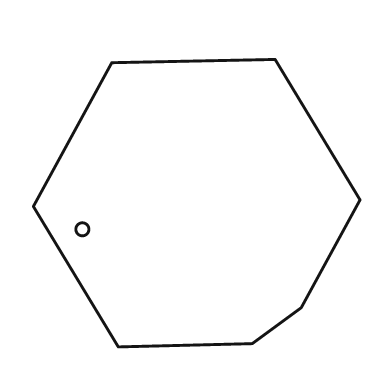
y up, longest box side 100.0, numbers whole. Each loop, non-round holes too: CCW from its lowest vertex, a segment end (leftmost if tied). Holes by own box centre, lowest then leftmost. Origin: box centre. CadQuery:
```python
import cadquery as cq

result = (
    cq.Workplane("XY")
    .moveTo(-24.0, -44.0)
    .lineTo(17.0, -43.0)
    .lineTo(32.0, -32.0)
    .lineTo(50.0, 1.0)
    .lineTo(24.0, 44.0)
    .lineTo(-26.0, 43.0)
    .lineTo(-50.0, -1.0)
    .close()
    .moveTo(-35.0, -8.0)
    .circle(2.0)
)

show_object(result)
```